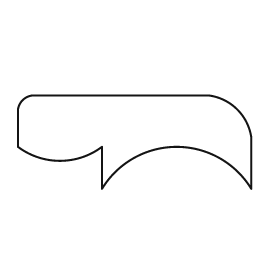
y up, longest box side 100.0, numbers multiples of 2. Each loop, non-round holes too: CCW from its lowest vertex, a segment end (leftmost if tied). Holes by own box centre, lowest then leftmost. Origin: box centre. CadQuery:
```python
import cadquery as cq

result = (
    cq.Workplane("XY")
    .moveTo(-14.0, -20.0)
    .threePointArc((18.0, -2.0), (50.0, -20.0))
    .lineTo(50.0, 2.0)
    .threePointArc((44.0, 14.0), (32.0, 20.0))
    .lineTo(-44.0, 20.0)
    .threePointArc((-48.0, 18.0), (-50.0, 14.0))
    .lineTo(-50.0, -2.0)
    .threePointArc((-32.0, -8.0), (-14.0, -2.0))
    .close()
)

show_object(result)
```